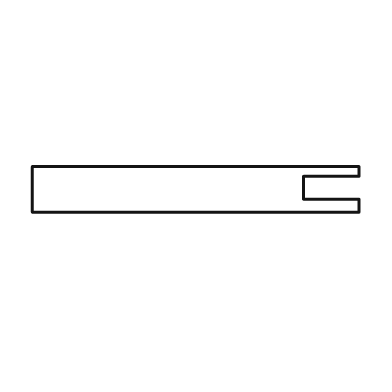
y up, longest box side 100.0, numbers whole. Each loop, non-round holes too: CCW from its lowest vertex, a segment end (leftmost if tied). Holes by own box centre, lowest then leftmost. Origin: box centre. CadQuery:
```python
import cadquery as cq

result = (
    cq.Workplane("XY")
    .moveTo(-50.0, -7.0)
    .lineTo(50.0, -7.0)
    .lineTo(50.0, -3.0)
    .lineTo(33.0, -3.0)
    .lineTo(33.0, 4.0)
    .lineTo(50.0, 4.0)
    .lineTo(50.0, 7.0)
    .lineTo(-50.0, 7.0)
    .close()
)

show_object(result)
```